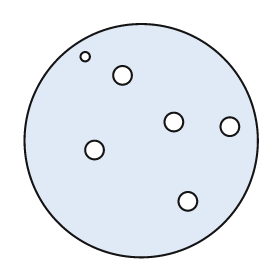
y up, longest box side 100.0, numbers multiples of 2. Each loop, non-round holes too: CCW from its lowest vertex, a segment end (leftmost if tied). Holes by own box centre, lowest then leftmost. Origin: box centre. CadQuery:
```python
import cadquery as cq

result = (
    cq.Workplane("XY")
    .moveTo(0.0, 0.0)
    .circle(50.0)
    .moveTo(20.0, -26.0)
    .circle(4.0)
    .moveTo(-20.0, -4.0)
    .circle(4.0)
    .moveTo(38.0, 6.0)
    .circle(4.0)
    .moveTo(14.0, 8.0)
    .circle(4.0)
    .moveTo(-8.0, 28.0)
    .circle(4.0)
    .moveTo(-24.0, 36.0)
    .circle(2.0)
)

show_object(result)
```